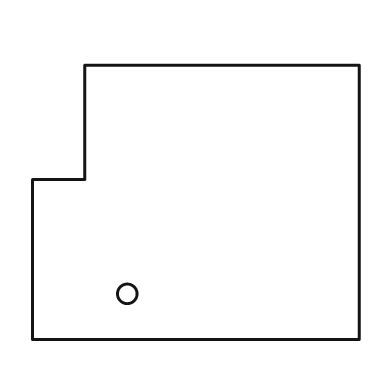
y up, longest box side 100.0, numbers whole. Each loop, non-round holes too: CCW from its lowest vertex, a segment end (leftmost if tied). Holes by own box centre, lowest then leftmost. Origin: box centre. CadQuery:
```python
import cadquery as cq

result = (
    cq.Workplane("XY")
    .moveTo(-50.0, -42.0)
    .lineTo(50.0, -42.0)
    .lineTo(50.0, 42.0)
    .lineTo(-34.0, 42.0)
    .lineTo(-34.0, 7.0)
    .lineTo(-50.0, 7.0)
    .close()
    .moveTo(-21.0, -28.0)
    .circle(3.0)
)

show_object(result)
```